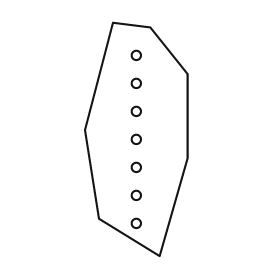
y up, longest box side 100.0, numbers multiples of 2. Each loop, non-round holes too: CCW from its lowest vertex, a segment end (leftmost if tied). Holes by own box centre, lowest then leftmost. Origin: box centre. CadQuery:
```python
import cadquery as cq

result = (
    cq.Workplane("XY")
    .moveTo(10.0, -50.0)
    .lineTo(22.0, -8.0)
    .lineTo(22.0, 28.0)
    .lineTo(6.0, 48.0)
    .lineTo(-10.0, 50.0)
    .lineTo(-22.0, 4.0)
    .lineTo(-16.0, -34.0)
    .close()
    .moveTo(0.0, -36.0)
    .circle(2.0)
    .moveTo(0.0, -24.0)
    .circle(2.0)
    .moveTo(0.0, -12.0)
    .circle(2.0)
    .moveTo(0.0, 0.0)
    .circle(2.0)
    .moveTo(0.0, 12.0)
    .circle(2.0)
    .moveTo(0.0, 24.0)
    .circle(2.0)
    .moveTo(0.0, 36.0)
    .circle(2.0)
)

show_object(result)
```